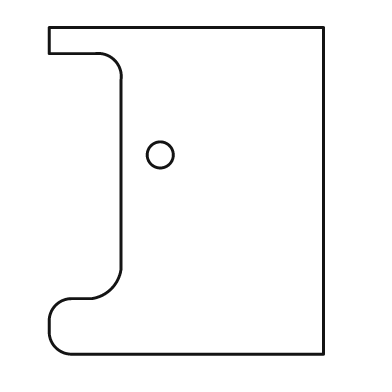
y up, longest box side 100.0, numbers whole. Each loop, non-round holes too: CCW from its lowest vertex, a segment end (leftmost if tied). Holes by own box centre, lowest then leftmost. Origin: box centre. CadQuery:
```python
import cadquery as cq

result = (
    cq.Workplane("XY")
    .moveTo(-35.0, -50.0)
    .lineTo(42.0, -50.0)
    .lineTo(42.0, 50.0)
    .lineTo(-42.0, 50.0)
    .lineTo(-42.0, 42.0)
    .lineTo(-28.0, 42.0)
    .threePointArc((-22.0, 40.0), (-20.0, 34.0))
    .lineTo(-20.0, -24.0)
    .threePointArc((-23.0, -30.0), (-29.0, -33.0))
    .lineTo(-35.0, -33.0)
    .threePointArc((-40.0, -35.0), (-42.0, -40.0))
    .lineTo(-42.0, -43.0)
    .threePointArc((-40.0, -48.0), (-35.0, -50.0))
    .close()
    .moveTo(-8.0, 11.0)
    .circle(4.0)
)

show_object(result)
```